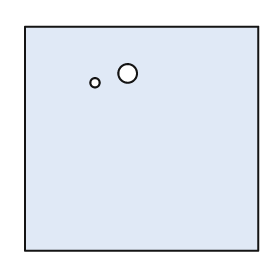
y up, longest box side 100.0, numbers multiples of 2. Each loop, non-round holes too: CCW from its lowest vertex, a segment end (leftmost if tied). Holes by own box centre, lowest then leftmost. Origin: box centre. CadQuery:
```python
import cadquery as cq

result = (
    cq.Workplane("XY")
    .moveTo(-50.0, -48.0)
    .lineTo(50.0, -48.0)
    .lineTo(50.0, 48.0)
    .lineTo(-50.0, 48.0)
    .close()
    .moveTo(-20.0, 24.0)
    .circle(2.0)
    .moveTo(-6.0, 28.0)
    .circle(4.0)
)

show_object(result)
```